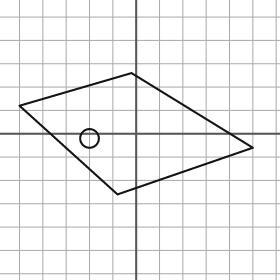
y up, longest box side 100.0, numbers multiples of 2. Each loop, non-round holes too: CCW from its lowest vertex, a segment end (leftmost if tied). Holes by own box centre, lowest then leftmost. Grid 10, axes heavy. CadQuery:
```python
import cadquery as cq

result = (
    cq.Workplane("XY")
    .moveTo(-8.0, -26.0)
    .lineTo(50.0, -6.0)
    .lineTo(-2.0, 26.0)
    .lineTo(-50.0, 12.0)
    .close()
    .moveTo(-20.0, -2.0)
    .circle(4.0)
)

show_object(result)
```